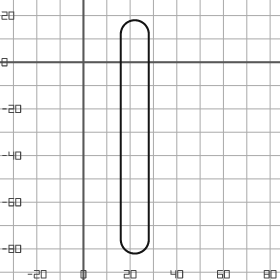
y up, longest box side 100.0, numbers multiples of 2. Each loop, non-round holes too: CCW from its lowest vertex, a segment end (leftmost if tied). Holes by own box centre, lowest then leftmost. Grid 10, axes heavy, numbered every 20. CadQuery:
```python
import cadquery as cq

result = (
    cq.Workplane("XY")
    .moveTo(16.0, -76.0)
    .threePointArc((22.0, -82.0), (28.0, -76.0))
    .lineTo(28.0, 12.0)
    .threePointArc((22.0, 18.0), (16.0, 12.0))
    .close()
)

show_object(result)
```